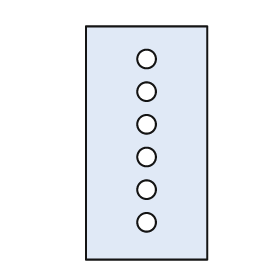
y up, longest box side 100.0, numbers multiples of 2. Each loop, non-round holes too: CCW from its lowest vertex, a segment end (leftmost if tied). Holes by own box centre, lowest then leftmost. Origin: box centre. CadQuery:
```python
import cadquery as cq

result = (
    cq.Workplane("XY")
    .moveTo(-26.0, -50.0)
    .lineTo(26.0, -50.0)
    .lineTo(26.0, 50.0)
    .lineTo(-26.0, 50.0)
    .close()
    .moveTo(0.0, -34.0)
    .circle(4.0)
    .moveTo(0.0, -20.0)
    .circle(4.0)
    .moveTo(0.0, -6.0)
    .circle(4.0)
    .moveTo(0.0, 8.0)
    .circle(4.0)
    .moveTo(0.0, 22.0)
    .circle(4.0)
    .moveTo(0.0, 36.0)
    .circle(4.0)
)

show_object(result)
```